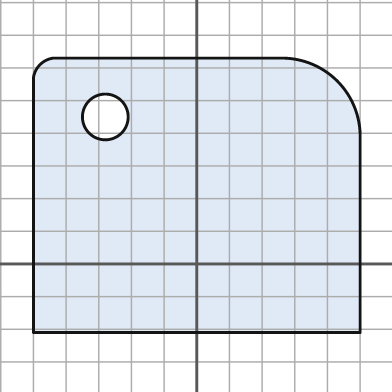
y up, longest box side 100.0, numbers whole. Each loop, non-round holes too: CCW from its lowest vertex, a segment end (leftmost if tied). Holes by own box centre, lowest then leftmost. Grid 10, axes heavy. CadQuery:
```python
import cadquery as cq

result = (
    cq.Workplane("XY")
    .moveTo(-50.0, -21.0)
    .lineTo(50.0, -21.0)
    .lineTo(50.0, 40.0)
    .threePointArc((43.0, 56.0), (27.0, 63.0))
    .lineTo(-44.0, 63.0)
    .threePointArc((-48.0, 61.0), (-50.0, 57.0))
    .close()
    .moveTo(-28.0, 45.0)
    .circle(7.0)
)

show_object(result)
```